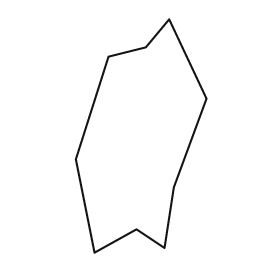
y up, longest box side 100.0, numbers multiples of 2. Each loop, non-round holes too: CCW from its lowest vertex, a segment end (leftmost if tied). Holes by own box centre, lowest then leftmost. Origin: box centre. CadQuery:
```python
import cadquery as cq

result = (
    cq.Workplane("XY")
    .moveTo(-20.0, -50.0)
    .lineTo(-2.0, -40.0)
    .lineTo(10.0, -48.0)
    .lineTo(14.0, -22.0)
    .lineTo(28.0, 16.0)
    .lineTo(12.0, 50.0)
    .lineTo(2.0, 38.0)
    .lineTo(-14.0, 34.0)
    .lineTo(-28.0, -10.0)
    .close()
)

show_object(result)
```